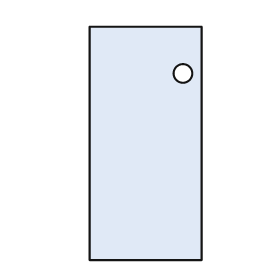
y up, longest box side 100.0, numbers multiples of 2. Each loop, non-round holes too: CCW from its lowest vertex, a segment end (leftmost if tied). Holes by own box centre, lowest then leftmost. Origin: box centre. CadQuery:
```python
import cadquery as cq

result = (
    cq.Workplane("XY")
    .moveTo(-24.0, -50.0)
    .lineTo(24.0, -50.0)
    .lineTo(24.0, 50.0)
    .lineTo(-24.0, 50.0)
    .close()
    .moveTo(16.0, 30.0)
    .circle(4.0)
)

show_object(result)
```